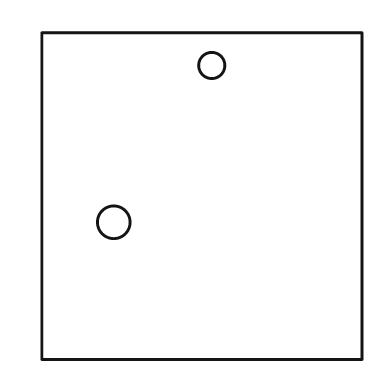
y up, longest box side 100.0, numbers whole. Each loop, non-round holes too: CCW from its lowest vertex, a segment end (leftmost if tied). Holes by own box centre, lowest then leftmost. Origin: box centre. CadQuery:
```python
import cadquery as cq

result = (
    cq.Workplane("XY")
    .moveTo(-49.0, -50.0)
    .lineTo(49.0, -50.0)
    .lineTo(49.0, 50.0)
    .lineTo(-49.0, 50.0)
    .close()
    .moveTo(-27.0, -8.0)
    .circle(5.0)
    .moveTo(3.0, 40.0)
    .circle(4.0)
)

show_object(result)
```